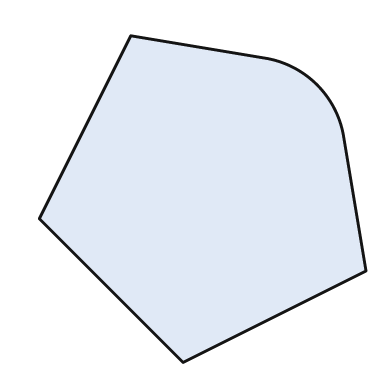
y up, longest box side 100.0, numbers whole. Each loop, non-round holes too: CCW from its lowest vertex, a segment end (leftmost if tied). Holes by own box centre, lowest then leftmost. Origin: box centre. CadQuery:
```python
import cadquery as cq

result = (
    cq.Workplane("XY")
    .moveTo(-6.0, -50.0)
    .lineTo(50.0, -22.0)
    .lineTo(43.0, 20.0)
    .threePointArc((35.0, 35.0), (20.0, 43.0))
    .lineTo(-22.0, 50.0)
    .lineTo(-50.0, -6.0)
    .close()
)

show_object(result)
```